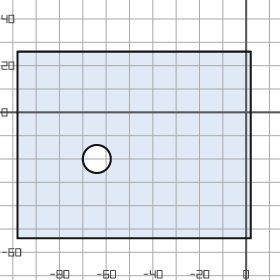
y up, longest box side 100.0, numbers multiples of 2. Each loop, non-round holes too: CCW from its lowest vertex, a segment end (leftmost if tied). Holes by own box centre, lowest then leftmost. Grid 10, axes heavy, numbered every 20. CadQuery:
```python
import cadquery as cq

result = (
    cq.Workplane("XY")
    .moveTo(-98.0, -54.0)
    .lineTo(2.0, -54.0)
    .lineTo(2.0, 26.0)
    .lineTo(-98.0, 26.0)
    .close()
    .moveTo(-64.0, -20.0)
    .circle(6.0)
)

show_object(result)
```